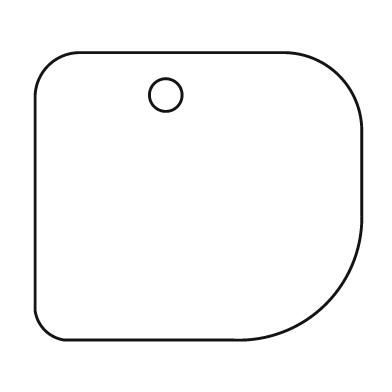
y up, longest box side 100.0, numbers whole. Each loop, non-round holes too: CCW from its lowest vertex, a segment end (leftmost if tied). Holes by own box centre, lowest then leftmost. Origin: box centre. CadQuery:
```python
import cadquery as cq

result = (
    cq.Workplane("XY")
    .moveTo(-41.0, -44.0)
    .lineTo(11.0, -44.0)
    .threePointArc((39.0, -33.0), (50.0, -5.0))
    .lineTo(50.0, 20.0)
    .threePointArc((43.0, 37.0), (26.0, 44.0))
    .lineTo(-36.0, 44.0)
    .threePointArc((-46.0, 40.0), (-50.0, 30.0))
    .lineTo(-50.0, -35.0)
    .threePointArc((-47.0, -41.0), (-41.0, -44.0))
    .close()
    .moveTo(-10.0, 31.0)
    .circle(5.0)
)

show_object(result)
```